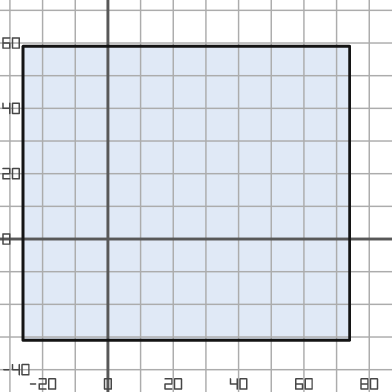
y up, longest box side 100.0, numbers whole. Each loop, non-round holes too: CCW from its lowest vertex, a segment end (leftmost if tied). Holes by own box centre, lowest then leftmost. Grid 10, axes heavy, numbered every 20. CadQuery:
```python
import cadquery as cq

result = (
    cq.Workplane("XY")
    .moveTo(-26.0, -31.0)
    .lineTo(74.0, -31.0)
    .lineTo(74.0, 59.0)
    .lineTo(-26.0, 59.0)
    .close()
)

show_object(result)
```